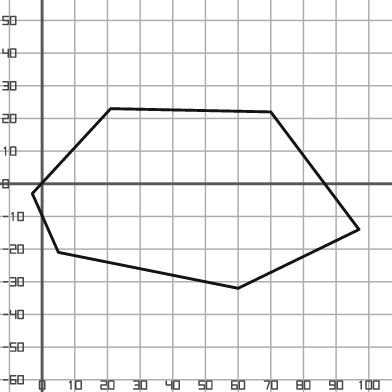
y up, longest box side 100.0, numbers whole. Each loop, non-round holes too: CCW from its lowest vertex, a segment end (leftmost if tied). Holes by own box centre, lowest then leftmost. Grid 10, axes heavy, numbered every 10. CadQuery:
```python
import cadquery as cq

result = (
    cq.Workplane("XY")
    .moveTo(60.0, -32.0)
    .lineTo(97.0, -14.0)
    .lineTo(70.0, 22.0)
    .lineTo(21.0, 23.0)
    .lineTo(-3.0, -3.0)
    .lineTo(5.0, -21.0)
    .close()
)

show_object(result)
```